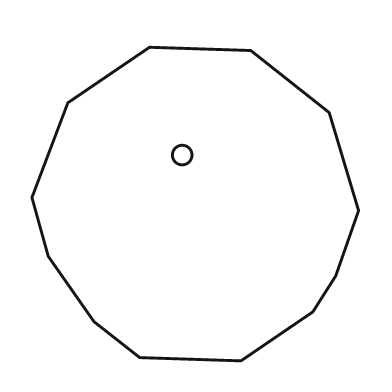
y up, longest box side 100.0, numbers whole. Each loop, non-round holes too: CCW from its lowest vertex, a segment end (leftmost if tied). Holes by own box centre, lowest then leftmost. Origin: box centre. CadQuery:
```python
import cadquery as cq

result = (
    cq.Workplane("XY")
    .moveTo(14.0, -48.0)
    .lineTo(36.0, -33.0)
    .lineTo(43.0, -22.0)
    .lineTo(50.0, -2.0)
    .lineTo(41.0, 28.0)
    .lineTo(17.0, 47.0)
    .lineTo(-14.0, 48.0)
    .lineTo(-39.0, 31.0)
    .lineTo(-50.0, 2.0)
    .lineTo(-45.0, -16.0)
    .lineTo(-31.0, -36.0)
    .lineTo(-17.0, -47.0)
    .close()
    .moveTo(-4.0, 15.0)
    .circle(3.0)
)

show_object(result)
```